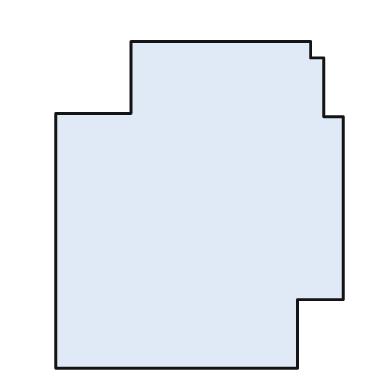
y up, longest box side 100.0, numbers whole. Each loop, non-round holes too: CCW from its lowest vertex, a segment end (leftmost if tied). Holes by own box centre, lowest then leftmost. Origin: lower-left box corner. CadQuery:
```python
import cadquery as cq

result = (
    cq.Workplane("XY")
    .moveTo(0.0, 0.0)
    .lineTo(74.0, 0.0)
    .lineTo(74.0, 21.0)
    .lineTo(88.0, 21.0)
    .lineTo(88.0, 77.0)
    .lineTo(82.0, 77.0)
    .lineTo(82.0, 95.0)
    .lineTo(78.0, 95.0)
    .lineTo(78.0, 100.0)
    .lineTo(23.0, 100.0)
    .lineTo(23.0, 78.0)
    .lineTo(0.0, 78.0)
    .close()
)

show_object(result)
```